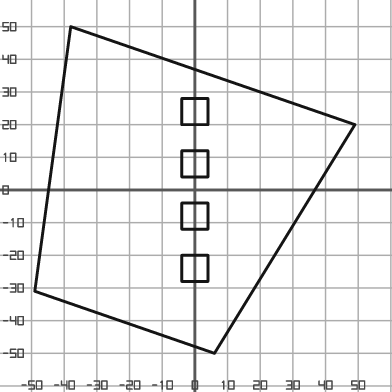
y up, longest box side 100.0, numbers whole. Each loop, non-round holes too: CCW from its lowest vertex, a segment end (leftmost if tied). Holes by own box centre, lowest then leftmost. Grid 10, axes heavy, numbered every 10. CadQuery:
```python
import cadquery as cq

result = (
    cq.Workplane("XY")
    .moveTo(6.0, -50.0)
    .lineTo(49.0, 20.0)
    .lineTo(-38.0, 50.0)
    .lineTo(-49.0, -31.0)
    .close()
    .moveTo(-4.0, -28.0)
    .lineTo(4.0, -28.0)
    .lineTo(4.0, -20.0)
    .lineTo(-4.0, -20.0)
    .close()
    .moveTo(-4.0, -12.0)
    .lineTo(4.0, -12.0)
    .lineTo(4.0, -4.0)
    .lineTo(-4.0, -4.0)
    .close()
    .moveTo(-4.0, 4.0)
    .lineTo(4.0, 4.0)
    .lineTo(4.0, 12.0)
    .lineTo(-4.0, 12.0)
    .close()
    .moveTo(-4.0, 20.0)
    .lineTo(4.0, 20.0)
    .lineTo(4.0, 28.0)
    .lineTo(-4.0, 28.0)
    .close()
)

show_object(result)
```